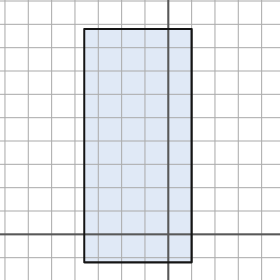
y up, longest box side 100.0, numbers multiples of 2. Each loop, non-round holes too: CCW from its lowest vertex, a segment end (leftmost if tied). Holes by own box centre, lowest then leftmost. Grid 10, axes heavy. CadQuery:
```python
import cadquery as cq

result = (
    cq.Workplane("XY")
    .moveTo(-36.0, -12.0)
    .lineTo(10.0, -12.0)
    .lineTo(10.0, 88.0)
    .lineTo(-36.0, 88.0)
    .close()
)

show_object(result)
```